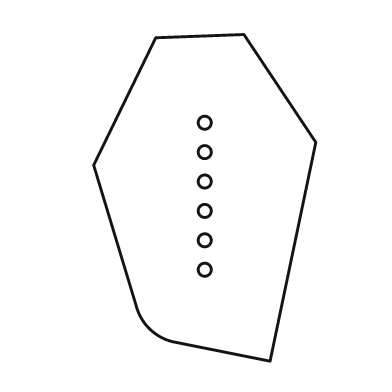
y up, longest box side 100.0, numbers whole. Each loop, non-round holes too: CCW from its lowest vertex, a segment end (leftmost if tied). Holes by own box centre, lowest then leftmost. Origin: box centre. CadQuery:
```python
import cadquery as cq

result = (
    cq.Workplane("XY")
    .moveTo(20.0, -50.0)
    .lineTo(34.0, 17.0)
    .lineTo(12.0, 50.0)
    .lineTo(-15.0, 49.0)
    .lineTo(-34.0, 10.0)
    .lineTo(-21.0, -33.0)
    .threePointArc((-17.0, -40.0), (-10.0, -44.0))
    .close()
    .moveTo(0.0, -22.0)
    .circle(2.0)
    .moveTo(0.0, -13.0)
    .circle(2.0)
    .moveTo(0.0, -4.0)
    .circle(2.0)
    .moveTo(0.0, 5.0)
    .circle(2.0)
    .moveTo(0.0, 14.0)
    .circle(2.0)
    .moveTo(0.0, 23.0)
    .circle(2.0)
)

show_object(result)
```